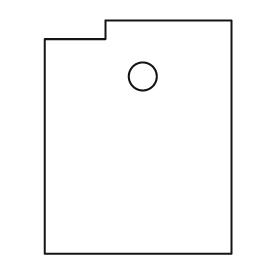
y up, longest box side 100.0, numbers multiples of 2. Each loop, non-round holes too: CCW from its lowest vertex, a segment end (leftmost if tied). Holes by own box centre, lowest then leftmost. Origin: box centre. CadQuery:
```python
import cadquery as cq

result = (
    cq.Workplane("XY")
    .moveTo(-40.0, -50.0)
    .lineTo(40.0, -50.0)
    .lineTo(40.0, 50.0)
    .lineTo(-14.0, 50.0)
    .lineTo(-14.0, 42.0)
    .lineTo(-40.0, 42.0)
    .close()
    .moveTo(2.0, 26.0)
    .circle(6.0)
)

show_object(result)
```